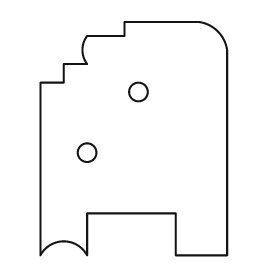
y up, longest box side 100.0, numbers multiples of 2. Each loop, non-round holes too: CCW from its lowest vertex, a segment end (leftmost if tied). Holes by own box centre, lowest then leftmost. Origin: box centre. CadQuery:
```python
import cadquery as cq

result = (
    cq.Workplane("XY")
    .moveTo(-40.0, -50.0)
    .threePointArc((-30.0, -44.0), (-20.0, -50.0))
    .lineTo(-20.0, -32.0)
    .lineTo(18.0, -32.0)
    .lineTo(18.0, -50.0)
    .lineTo(40.0, -50.0)
    .lineTo(40.0, 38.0)
    .threePointArc((36.0, 46.0), (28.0, 50.0))
    .lineTo(-4.0, 50.0)
    .lineTo(-4.0, 44.0)
    .lineTo(-20.0, 44.0)
    .threePointArc((-22.0, 38.0), (-20.0, 32.0))
    .lineTo(-30.0, 32.0)
    .lineTo(-30.0, 24.0)
    .lineTo(-40.0, 24.0)
    .close()
    .moveTo(-20.0, -6.0)
    .circle(4.0)
    .moveTo(2.0, 20.0)
    .circle(4.0)
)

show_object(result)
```